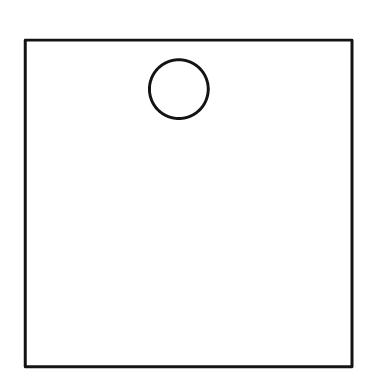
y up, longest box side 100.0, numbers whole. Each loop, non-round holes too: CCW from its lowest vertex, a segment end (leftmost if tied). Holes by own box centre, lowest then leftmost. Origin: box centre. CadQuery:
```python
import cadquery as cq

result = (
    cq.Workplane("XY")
    .moveTo(-50.0, -50.0)
    .lineTo(50.0, -50.0)
    .lineTo(50.0, 50.0)
    .lineTo(-50.0, 50.0)
    .close()
    .moveTo(-3.0, 35.0)
    .circle(9.0)
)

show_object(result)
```